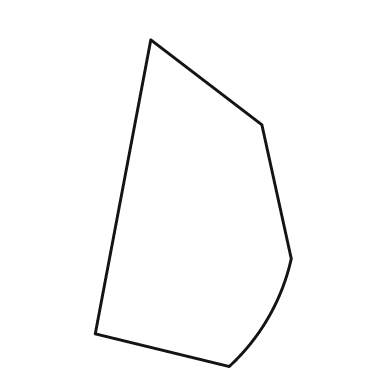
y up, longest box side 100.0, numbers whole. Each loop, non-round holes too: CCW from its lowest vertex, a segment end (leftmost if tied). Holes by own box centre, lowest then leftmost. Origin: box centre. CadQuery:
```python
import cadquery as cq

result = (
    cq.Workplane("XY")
    .moveTo(11.0, -50.0)
    .threePointArc((23.0, -35.0), (30.0, -17.0))
    .lineTo(21.0, 24.0)
    .lineTo(-13.0, 50.0)
    .lineTo(-30.0, -40.0)
    .close()
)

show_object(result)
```